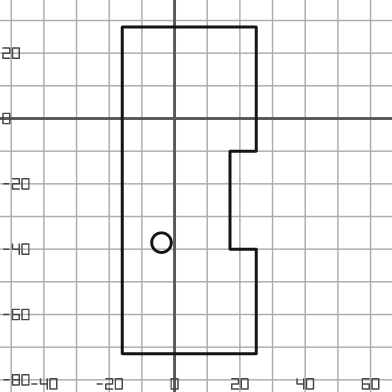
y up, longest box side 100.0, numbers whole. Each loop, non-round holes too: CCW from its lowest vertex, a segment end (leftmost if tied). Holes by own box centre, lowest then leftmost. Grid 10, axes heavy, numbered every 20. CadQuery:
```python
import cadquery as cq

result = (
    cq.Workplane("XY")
    .moveTo(-16.0, -72.0)
    .lineTo(25.0, -72.0)
    .lineTo(25.0, -40.0)
    .lineTo(17.0, -40.0)
    .lineTo(17.0, -10.0)
    .lineTo(25.0, -10.0)
    .lineTo(25.0, 28.0)
    .lineTo(-16.0, 28.0)
    .close()
    .moveTo(-4.0, -38.0)
    .circle(3.0)
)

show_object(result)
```